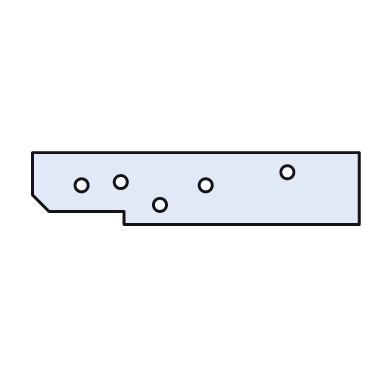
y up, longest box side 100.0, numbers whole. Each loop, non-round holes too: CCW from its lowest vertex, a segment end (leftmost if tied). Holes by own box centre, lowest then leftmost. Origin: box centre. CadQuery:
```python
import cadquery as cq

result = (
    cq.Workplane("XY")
    .moveTo(-22.0, -11.0)
    .lineTo(50.0, -11.0)
    .lineTo(50.0, 11.0)
    .lineTo(-50.0, 11.0)
    .lineTo(-50.0, -2.0)
    .lineTo(-45.0, -7.0)
    .lineTo(-22.0, -7.0)
    .close()
    .moveTo(-11.0, -5.0)
    .circle(2.0)
    .moveTo(-35.0, 1.0)
    .circle(2.0)
    .moveTo(3.0, 1.0)
    .circle(2.0)
    .moveTo(-23.0, 2.0)
    .circle(2.0)
    .moveTo(28.0, 5.0)
    .circle(2.0)
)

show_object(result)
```